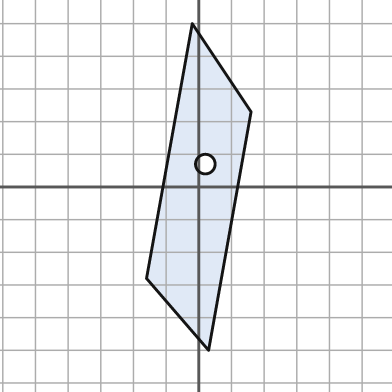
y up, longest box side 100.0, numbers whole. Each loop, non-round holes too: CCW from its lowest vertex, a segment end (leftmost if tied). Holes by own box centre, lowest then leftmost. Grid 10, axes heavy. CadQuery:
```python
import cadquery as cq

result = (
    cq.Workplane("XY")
    .moveTo(3.0, -50.0)
    .lineTo(16.0, 23.0)
    .lineTo(-2.0, 50.0)
    .lineTo(-16.0, -28.0)
    .close()
    .moveTo(2.0, 7.0)
    .circle(3.0)
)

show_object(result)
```